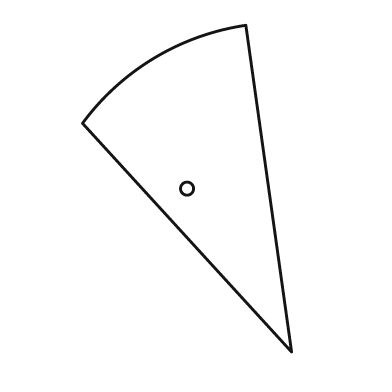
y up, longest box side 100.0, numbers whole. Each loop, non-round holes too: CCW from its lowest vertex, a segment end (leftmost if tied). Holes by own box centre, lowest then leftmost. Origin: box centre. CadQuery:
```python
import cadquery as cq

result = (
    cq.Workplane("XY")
    .moveTo(32.0, -50.0)
    .lineTo(18.0, 50.0)
    .threePointArc((-10.0, 40.0), (-32.0, 20.0))
    .close()
    .moveTo(0.0, 0.0)
    .circle(2.0)
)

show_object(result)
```